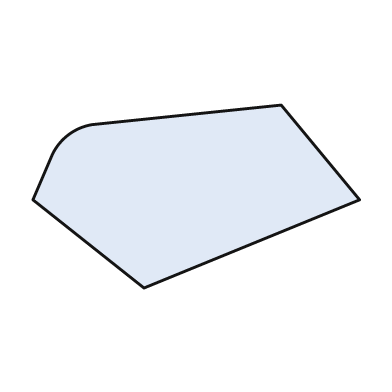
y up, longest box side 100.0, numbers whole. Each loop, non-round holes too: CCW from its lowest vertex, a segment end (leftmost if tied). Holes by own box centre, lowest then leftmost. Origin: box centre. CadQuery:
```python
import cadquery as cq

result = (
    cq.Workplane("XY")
    .moveTo(-16.0, -28.0)
    .lineTo(50.0, -1.0)
    .lineTo(26.0, 28.0)
    .lineTo(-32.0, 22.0)
    .threePointArc((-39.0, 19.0), (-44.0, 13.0))
    .lineTo(-50.0, -1.0)
    .close()
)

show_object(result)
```